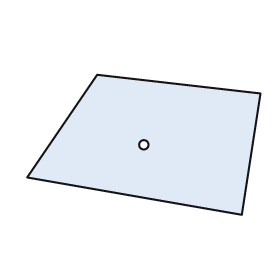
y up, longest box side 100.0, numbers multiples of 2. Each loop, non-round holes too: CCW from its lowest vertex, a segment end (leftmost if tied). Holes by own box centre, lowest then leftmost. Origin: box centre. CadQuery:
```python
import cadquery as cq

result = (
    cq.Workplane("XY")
    .moveTo(42.0, -30.0)
    .lineTo(50.0, 22.0)
    .lineTo(-20.0, 30.0)
    .lineTo(-50.0, -14.0)
    .close()
    .moveTo(0.0, 0.0)
    .circle(2.0)
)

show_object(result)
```